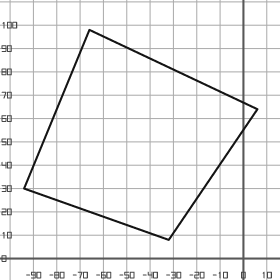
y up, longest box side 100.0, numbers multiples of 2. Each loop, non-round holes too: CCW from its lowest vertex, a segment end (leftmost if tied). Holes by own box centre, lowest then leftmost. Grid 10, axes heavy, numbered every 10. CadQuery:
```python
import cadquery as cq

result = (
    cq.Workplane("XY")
    .moveTo(-32.0, 8.0)
    .lineTo(6.0, 64.0)
    .lineTo(-66.0, 98.0)
    .lineTo(-94.0, 30.0)
    .close()
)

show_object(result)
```